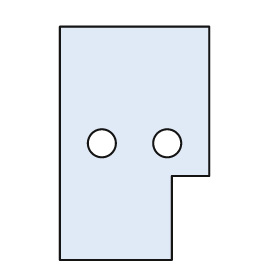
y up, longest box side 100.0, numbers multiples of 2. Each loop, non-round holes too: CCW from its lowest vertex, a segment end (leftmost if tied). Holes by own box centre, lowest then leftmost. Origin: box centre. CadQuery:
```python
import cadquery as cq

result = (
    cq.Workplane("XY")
    .moveTo(-32.0, -50.0)
    .lineTo(16.0, -50.0)
    .lineTo(16.0, -14.0)
    .lineTo(32.0, -14.0)
    .lineTo(32.0, 50.0)
    .lineTo(-32.0, 50.0)
    .close()
    .moveTo(-14.0, 0.0)
    .circle(6.0)
    .moveTo(14.0, 0.0)
    .circle(6.0)
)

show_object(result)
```